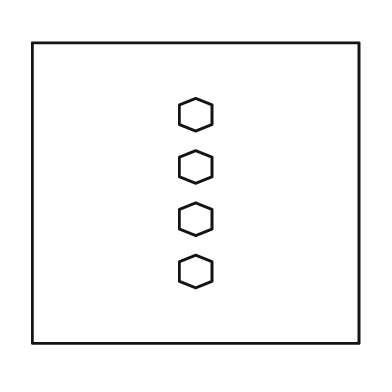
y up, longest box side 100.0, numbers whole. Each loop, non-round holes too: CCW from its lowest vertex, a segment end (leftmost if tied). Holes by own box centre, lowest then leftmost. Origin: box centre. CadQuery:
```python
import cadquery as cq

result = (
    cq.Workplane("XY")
    .moveTo(-50.0, -46.0)
    .lineTo(50.0, -46.0)
    .lineTo(50.0, 46.0)
    .lineTo(-50.0, 46.0)
    .close()
    .moveTo(0.0, -29.0)
    .lineTo(5.0, -27.0)
    .lineTo(5.0, -21.0)
    .lineTo(0.0, -19.0)
    .lineTo(-5.0, -21.0)
    .lineTo(-5.0, -27.0)
    .close()
    .moveTo(0.0, -13.0)
    .lineTo(5.0, -11.0)
    .lineTo(5.0, -5.0)
    .lineTo(0.0, -3.0)
    .lineTo(-5.0, -5.0)
    .lineTo(-5.0, -11.0)
    .close()
    .moveTo(0.0, 3.0)
    .lineTo(5.0, 5.0)
    .lineTo(5.0, 11.0)
    .lineTo(0.0, 13.0)
    .lineTo(-5.0, 11.0)
    .lineTo(-5.0, 5.0)
    .close()
    .moveTo(0.0, 19.0)
    .lineTo(5.0, 21.0)
    .lineTo(5.0, 27.0)
    .lineTo(0.0, 29.0)
    .lineTo(-5.0, 27.0)
    .lineTo(-5.0, 21.0)
    .close()
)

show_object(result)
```